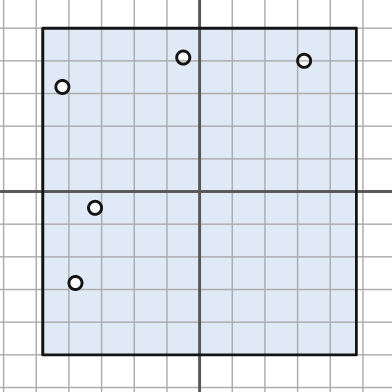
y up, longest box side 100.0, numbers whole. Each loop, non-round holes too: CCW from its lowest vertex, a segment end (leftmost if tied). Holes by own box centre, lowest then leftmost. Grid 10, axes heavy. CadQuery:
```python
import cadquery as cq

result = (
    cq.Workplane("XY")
    .moveTo(-48.0, -50.0)
    .lineTo(48.0, -50.0)
    .lineTo(48.0, 50.0)
    .lineTo(-48.0, 50.0)
    .close()
    .moveTo(-38.0, -28.0)
    .circle(2.0)
    .moveTo(-32.0, -5.0)
    .circle(2.0)
    .moveTo(-42.0, 32.0)
    .circle(2.0)
    .moveTo(32.0, 40.0)
    .circle(2.0)
    .moveTo(-5.0, 41.0)
    .circle(2.0)
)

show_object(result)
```